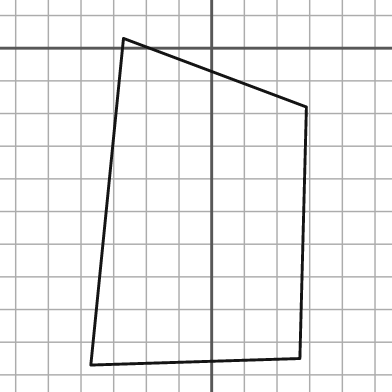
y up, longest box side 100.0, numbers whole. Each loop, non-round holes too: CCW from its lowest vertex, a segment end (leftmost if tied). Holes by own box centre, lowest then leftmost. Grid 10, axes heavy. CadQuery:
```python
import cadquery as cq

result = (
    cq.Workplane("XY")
    .moveTo(-37.0, -97.0)
    .lineTo(27.0, -95.0)
    .lineTo(29.0, -18.0)
    .lineTo(-27.0, 3.0)
    .close()
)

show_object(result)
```